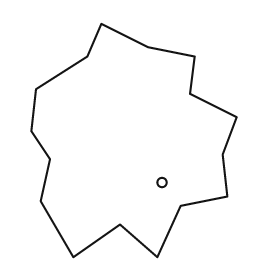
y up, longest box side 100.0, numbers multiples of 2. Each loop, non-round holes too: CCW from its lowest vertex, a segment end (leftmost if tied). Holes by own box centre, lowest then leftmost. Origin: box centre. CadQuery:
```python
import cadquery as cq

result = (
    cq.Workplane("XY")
    .moveTo(-26.0, -50.0)
    .lineTo(-6.0, -36.0)
    .lineTo(10.0, -50.0)
    .lineTo(20.0, -28.0)
    .lineTo(40.0, -24.0)
    .lineTo(38.0, -6.0)
    .lineTo(44.0, 10.0)
    .lineTo(24.0, 20.0)
    .lineTo(26.0, 36.0)
    .lineTo(6.0, 40.0)
    .lineTo(-14.0, 50.0)
    .lineTo(-20.0, 36.0)
    .lineTo(-42.0, 22.0)
    .lineTo(-44.0, 4.0)
    .lineTo(-36.0, -8.0)
    .lineTo(-40.0, -26.0)
    .close()
    .moveTo(12.0, -18.0)
    .circle(2.0)
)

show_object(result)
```